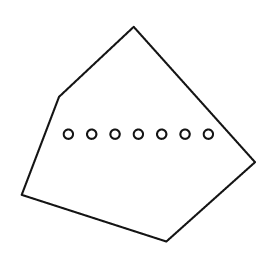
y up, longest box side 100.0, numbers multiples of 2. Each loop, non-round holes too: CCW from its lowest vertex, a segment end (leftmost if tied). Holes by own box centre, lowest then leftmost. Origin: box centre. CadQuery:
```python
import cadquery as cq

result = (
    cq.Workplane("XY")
    .moveTo(12.0, -46.0)
    .lineTo(50.0, -12.0)
    .lineTo(-2.0, 46.0)
    .lineTo(-34.0, 16.0)
    .lineTo(-50.0, -26.0)
    .close()
    .moveTo(-30.0, 0.0)
    .circle(2.0)
    .moveTo(-20.0, 0.0)
    .circle(2.0)
    .moveTo(-10.0, 0.0)
    .circle(2.0)
    .moveTo(0.0, 0.0)
    .circle(2.0)
    .moveTo(10.0, 0.0)
    .circle(2.0)
    .moveTo(20.0, 0.0)
    .circle(2.0)
    .moveTo(30.0, 0.0)
    .circle(2.0)
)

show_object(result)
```